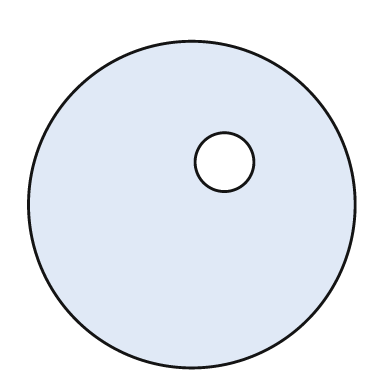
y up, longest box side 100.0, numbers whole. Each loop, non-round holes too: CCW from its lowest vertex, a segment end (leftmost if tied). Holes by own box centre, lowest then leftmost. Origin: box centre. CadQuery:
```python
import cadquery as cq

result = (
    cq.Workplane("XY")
    .moveTo(0.0, 0.0)
    .circle(50.0)
    .moveTo(10.0, 13.0)
    .circle(9.0)
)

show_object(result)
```